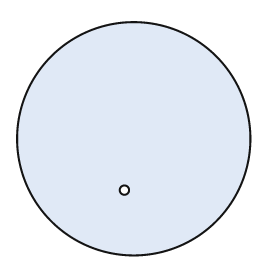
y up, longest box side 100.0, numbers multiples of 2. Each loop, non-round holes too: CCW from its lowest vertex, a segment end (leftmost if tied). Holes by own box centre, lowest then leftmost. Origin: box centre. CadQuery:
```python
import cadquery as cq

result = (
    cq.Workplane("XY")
    .moveTo(0.0, 0.0)
    .circle(50.0)
    .moveTo(-4.0, -22.0)
    .circle(2.0)
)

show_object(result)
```